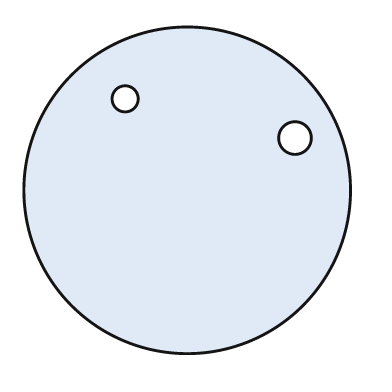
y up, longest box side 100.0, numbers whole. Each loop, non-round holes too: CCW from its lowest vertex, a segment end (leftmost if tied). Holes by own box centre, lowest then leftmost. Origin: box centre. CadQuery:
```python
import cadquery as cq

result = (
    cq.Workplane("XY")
    .moveTo(0.0, 0.0)
    .circle(50.0)
    .moveTo(33.0, 16.0)
    .circle(5.0)
    .moveTo(-19.0, 28.0)
    .circle(4.0)
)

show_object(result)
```